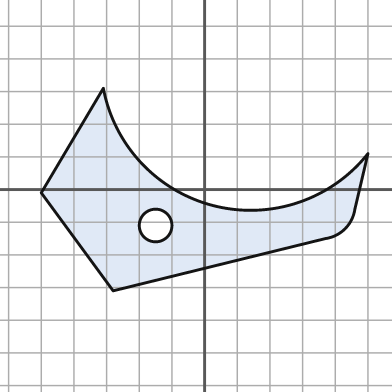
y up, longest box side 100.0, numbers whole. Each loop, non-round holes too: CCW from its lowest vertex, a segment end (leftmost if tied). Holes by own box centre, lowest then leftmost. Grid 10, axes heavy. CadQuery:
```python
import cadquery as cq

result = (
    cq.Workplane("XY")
    .moveTo(-28.0, -31.0)
    .lineTo(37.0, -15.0)
    .threePointArc((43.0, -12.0), (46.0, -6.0))
    .lineTo(50.0, 11.0)
    .threePointArc((3.0, -5.0), (-31.0, 31.0))
    .lineTo(-50.0, -1.0)
    .close()
    .moveTo(-15.0, -11.0)
    .circle(5.0)
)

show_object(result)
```